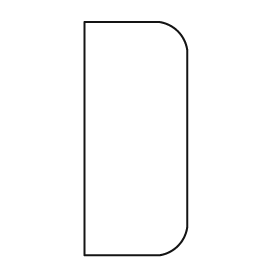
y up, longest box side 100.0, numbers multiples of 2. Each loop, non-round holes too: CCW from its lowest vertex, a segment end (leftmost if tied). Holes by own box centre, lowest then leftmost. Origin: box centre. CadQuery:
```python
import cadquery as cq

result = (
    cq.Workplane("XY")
    .moveTo(-22.0, -50.0)
    .lineTo(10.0, -50.0)
    .threePointArc((18.0, -46.0), (22.0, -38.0))
    .lineTo(22.0, 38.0)
    .threePointArc((18.0, 46.0), (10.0, 50.0))
    .lineTo(-22.0, 50.0)
    .close()
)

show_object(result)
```